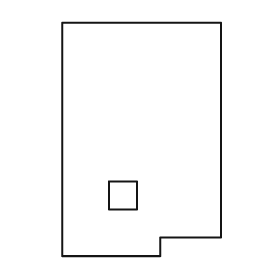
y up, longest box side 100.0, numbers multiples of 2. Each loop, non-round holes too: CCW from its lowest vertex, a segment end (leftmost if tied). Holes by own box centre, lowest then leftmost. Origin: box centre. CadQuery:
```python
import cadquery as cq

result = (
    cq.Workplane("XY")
    .moveTo(-34.0, -50.0)
    .lineTo(8.0, -50.0)
    .lineTo(8.0, -42.0)
    .lineTo(34.0, -42.0)
    .lineTo(34.0, 50.0)
    .lineTo(-34.0, 50.0)
    .close()
    .moveTo(-14.0, -30.0)
    .lineTo(-2.0, -30.0)
    .lineTo(-2.0, -18.0)
    .lineTo(-14.0, -18.0)
    .close()
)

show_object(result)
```